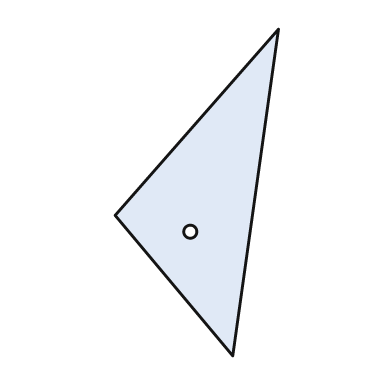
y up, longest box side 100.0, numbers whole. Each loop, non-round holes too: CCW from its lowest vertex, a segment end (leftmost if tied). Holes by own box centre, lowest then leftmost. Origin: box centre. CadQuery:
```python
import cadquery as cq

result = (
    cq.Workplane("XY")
    .moveTo(11.0, -50.0)
    .lineTo(25.0, 50.0)
    .lineTo(-25.0, -7.0)
    .close()
    .moveTo(-2.0, -12.0)
    .circle(2.0)
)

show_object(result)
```